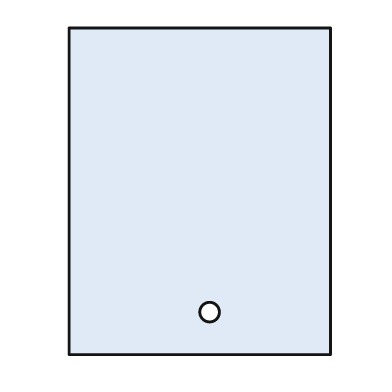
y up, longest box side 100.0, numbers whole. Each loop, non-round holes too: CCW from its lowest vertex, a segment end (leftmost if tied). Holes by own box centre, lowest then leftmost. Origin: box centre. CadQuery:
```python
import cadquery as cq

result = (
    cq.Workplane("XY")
    .moveTo(-40.0, -50.0)
    .lineTo(40.0, -50.0)
    .lineTo(40.0, 50.0)
    .lineTo(-40.0, 50.0)
    .close()
    .moveTo(3.0, -37.0)
    .circle(3.0)
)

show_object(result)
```